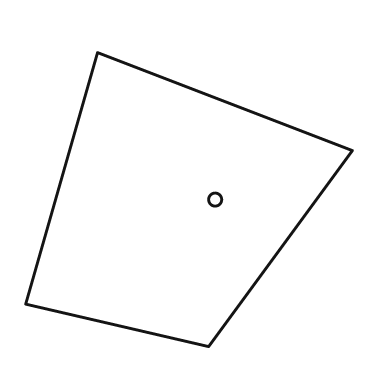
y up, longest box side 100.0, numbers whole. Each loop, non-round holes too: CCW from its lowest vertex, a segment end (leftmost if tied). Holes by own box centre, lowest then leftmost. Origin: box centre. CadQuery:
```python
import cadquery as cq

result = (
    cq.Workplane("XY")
    .moveTo(6.0, -45.0)
    .lineTo(50.0, 15.0)
    .lineTo(-28.0, 45.0)
    .lineTo(-50.0, -32.0)
    .close()
    .moveTo(8.0, 0.0)
    .circle(2.0)
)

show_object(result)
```